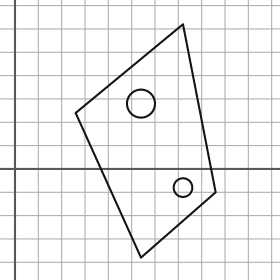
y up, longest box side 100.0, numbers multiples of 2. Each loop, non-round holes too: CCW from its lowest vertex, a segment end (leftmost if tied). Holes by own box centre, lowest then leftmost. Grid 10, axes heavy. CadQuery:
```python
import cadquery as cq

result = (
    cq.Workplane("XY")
    .moveTo(54.0, -38.0)
    .lineTo(86.0, -10.0)
    .lineTo(72.0, 62.0)
    .lineTo(26.0, 24.0)
    .close()
    .moveTo(72.0, -8.0)
    .circle(4.0)
    .moveTo(54.0, 28.0)
    .circle(6.0)
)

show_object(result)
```